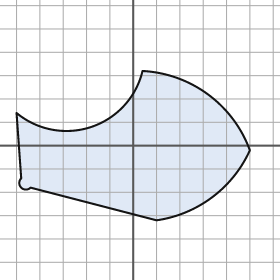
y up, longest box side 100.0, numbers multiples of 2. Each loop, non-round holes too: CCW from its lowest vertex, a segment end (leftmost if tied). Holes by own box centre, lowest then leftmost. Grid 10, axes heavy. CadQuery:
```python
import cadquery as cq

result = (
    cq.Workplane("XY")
    .moveTo(10.0, -32.0)
    .threePointArc((34.0, -22.0), (50.0, -2.0))
    .threePointArc((32.0, 22.0), (4.0, 32.0))
    .threePointArc((-18.0, 8.0), (-50.0, 14.0))
    .lineTo(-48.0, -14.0)
    .threePointArc((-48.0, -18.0), (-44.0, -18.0))
    .close()
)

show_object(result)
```